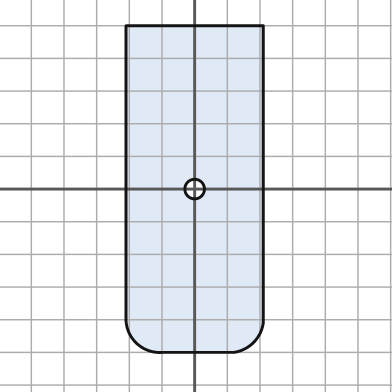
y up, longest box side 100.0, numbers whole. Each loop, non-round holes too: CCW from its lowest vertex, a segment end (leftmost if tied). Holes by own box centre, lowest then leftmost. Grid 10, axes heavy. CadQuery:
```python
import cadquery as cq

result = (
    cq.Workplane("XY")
    .moveTo(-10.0, -50.0)
    .lineTo(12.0, -50.0)
    .threePointArc((18.0, -47.0), (21.0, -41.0))
    .lineTo(21.0, 50.0)
    .lineTo(-21.0, 50.0)
    .lineTo(-21.0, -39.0)
    .threePointArc((-18.0, -47.0), (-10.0, -50.0))
    .close()
    .moveTo(0.0, 0.0)
    .circle(3.0)
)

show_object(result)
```